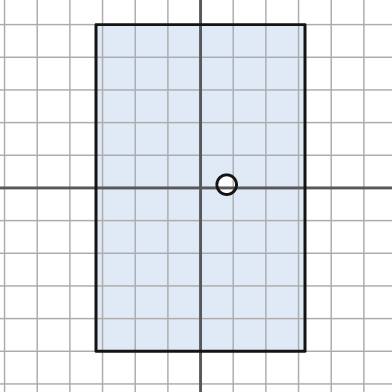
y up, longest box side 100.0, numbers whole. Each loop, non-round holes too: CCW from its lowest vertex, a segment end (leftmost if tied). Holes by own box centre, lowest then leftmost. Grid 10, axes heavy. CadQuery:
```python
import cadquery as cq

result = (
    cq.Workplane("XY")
    .moveTo(-32.0, -50.0)
    .lineTo(32.0, -50.0)
    .lineTo(32.0, 50.0)
    .lineTo(-32.0, 50.0)
    .close()
    .moveTo(8.0, 1.0)
    .circle(3.0)
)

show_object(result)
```